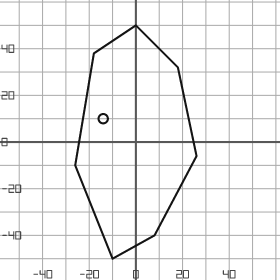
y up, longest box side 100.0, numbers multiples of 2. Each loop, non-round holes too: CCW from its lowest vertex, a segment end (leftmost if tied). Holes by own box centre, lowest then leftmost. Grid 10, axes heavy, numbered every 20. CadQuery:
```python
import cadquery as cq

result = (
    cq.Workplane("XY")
    .moveTo(-10.0, -50.0)
    .lineTo(8.0, -40.0)
    .lineTo(26.0, -6.0)
    .lineTo(18.0, 32.0)
    .lineTo(0.0, 50.0)
    .lineTo(-18.0, 38.0)
    .lineTo(-26.0, -10.0)
    .close()
    .moveTo(-14.0, 10.0)
    .circle(2.0)
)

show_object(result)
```